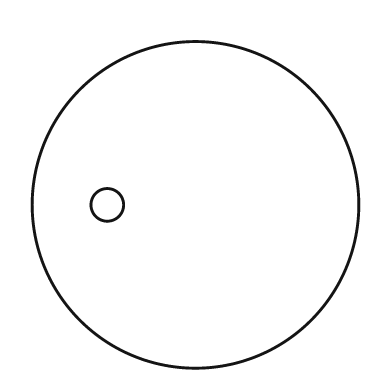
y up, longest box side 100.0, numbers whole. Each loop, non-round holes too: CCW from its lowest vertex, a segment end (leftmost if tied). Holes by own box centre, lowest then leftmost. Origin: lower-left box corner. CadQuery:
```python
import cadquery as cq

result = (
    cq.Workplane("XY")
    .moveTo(50.0, 50.0)
    .circle(50.0)
    .moveTo(23.0, 50.0)
    .circle(5.0)
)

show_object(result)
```